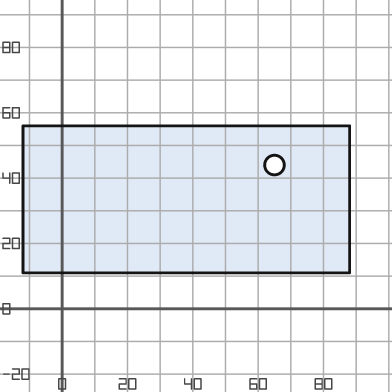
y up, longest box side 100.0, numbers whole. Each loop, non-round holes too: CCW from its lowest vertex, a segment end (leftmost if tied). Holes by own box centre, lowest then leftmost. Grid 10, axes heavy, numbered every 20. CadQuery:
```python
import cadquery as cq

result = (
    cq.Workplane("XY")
    .moveTo(-12.0, 11.0)
    .lineTo(88.0, 11.0)
    .lineTo(88.0, 56.0)
    .lineTo(-12.0, 56.0)
    .close()
    .moveTo(65.0, 44.0)
    .circle(3.0)
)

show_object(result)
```